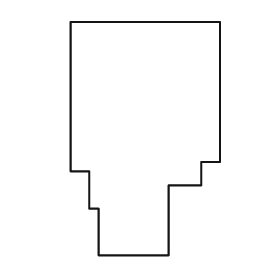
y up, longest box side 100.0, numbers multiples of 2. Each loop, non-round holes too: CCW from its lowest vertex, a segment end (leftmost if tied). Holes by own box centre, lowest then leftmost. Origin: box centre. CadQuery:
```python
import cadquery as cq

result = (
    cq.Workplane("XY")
    .moveTo(-20.0, -50.0)
    .lineTo(10.0, -50.0)
    .lineTo(10.0, -20.0)
    .lineTo(24.0, -20.0)
    .lineTo(24.0, -10.0)
    .lineTo(32.0, -10.0)
    .lineTo(32.0, 50.0)
    .lineTo(-32.0, 50.0)
    .lineTo(-32.0, -14.0)
    .lineTo(-24.0, -14.0)
    .lineTo(-24.0, -30.0)
    .lineTo(-20.0, -30.0)
    .close()
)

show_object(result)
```